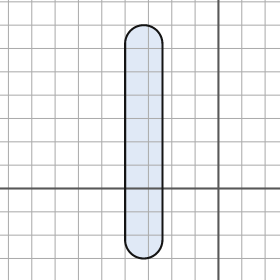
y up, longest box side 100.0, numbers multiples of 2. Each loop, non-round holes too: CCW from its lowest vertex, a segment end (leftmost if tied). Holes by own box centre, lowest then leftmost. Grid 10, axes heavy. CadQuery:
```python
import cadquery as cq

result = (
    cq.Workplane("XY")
    .moveTo(-40.0, -22.0)
    .threePointArc((-32.0, -30.0), (-24.0, -22.0))
    .lineTo(-24.0, 62.0)
    .threePointArc((-32.0, 70.0), (-40.0, 62.0))
    .close()
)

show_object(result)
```